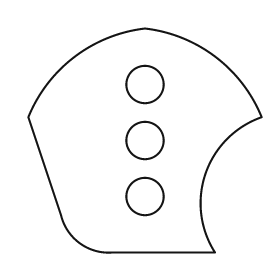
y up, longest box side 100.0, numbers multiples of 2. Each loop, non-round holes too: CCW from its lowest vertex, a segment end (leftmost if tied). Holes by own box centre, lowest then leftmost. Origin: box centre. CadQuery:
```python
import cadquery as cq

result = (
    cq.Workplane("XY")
    .moveTo(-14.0, -48.0)
    .lineTo(30.0, -48.0)
    .threePointArc((26.0, -14.0), (50.0, 10.0))
    .threePointArc((30.0, 36.0), (0.0, 48.0))
    .threePointArc((-30.0, 36.0), (-50.0, 10.0))
    .lineTo(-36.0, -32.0)
    .threePointArc((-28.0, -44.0), (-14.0, -48.0))
    .close()
    .moveTo(0.0, -24.0)
    .circle(8.0)
    .moveTo(0.0, 0.0)
    .circle(8.0)
    .moveTo(0.0, 24.0)
    .circle(8.0)
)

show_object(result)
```